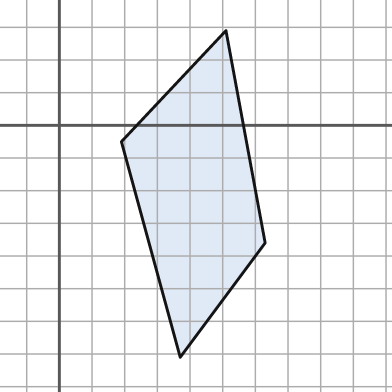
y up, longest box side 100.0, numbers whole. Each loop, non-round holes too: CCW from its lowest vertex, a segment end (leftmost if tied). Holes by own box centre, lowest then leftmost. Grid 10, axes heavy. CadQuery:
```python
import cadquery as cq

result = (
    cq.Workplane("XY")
    .moveTo(37.0, -71.0)
    .lineTo(63.0, -36.0)
    .lineTo(51.0, 29.0)
    .lineTo(19.0, -5.0)
    .close()
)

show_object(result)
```